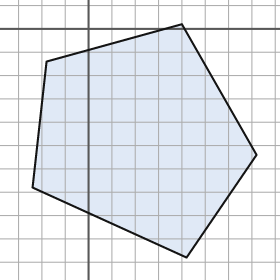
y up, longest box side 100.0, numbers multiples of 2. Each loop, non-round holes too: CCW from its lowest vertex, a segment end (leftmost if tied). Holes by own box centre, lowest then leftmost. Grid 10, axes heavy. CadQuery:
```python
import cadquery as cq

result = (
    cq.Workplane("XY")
    .moveTo(42.0, -98.0)
    .lineTo(72.0, -54.0)
    .lineTo(40.0, 2.0)
    .lineTo(-18.0, -14.0)
    .lineTo(-24.0, -68.0)
    .close()
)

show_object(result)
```